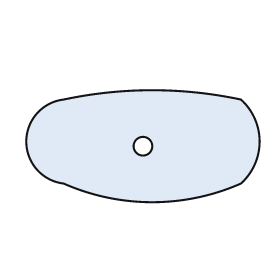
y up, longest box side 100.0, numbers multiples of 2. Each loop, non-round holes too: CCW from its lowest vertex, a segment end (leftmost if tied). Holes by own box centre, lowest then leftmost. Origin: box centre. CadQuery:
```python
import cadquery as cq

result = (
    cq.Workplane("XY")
    .moveTo(-34.0, -16.0)
    .threePointArc((4.0, -24.0), (42.0, -16.0))
    .threePointArc((50.0, 2.0), (42.0, 20.0))
    .threePointArc((4.0, 24.0), (-34.0, 20.0))
    .threePointArc((-50.0, 2.0), (-34.0, -16.0))
    .close()
    .moveTo(0.0, 0.0)
    .circle(4.0)
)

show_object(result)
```